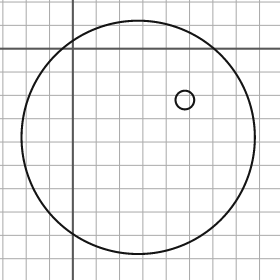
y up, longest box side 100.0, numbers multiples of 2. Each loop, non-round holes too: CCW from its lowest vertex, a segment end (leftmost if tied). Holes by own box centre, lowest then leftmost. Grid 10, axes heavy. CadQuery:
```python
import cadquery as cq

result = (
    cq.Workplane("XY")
    .moveTo(28.0, -38.0)
    .circle(50.0)
    .moveTo(48.0, -22.0)
    .circle(4.0)
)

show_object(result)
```